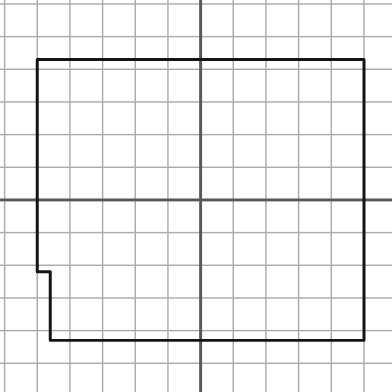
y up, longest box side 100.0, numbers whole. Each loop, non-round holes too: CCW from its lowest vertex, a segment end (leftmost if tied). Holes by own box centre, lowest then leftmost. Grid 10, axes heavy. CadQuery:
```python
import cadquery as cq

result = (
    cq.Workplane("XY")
    .moveTo(-46.0, -43.0)
    .lineTo(50.0, -43.0)
    .lineTo(50.0, 43.0)
    .lineTo(-50.0, 43.0)
    .lineTo(-50.0, -22.0)
    .lineTo(-46.0, -22.0)
    .close()
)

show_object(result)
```